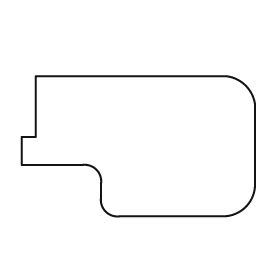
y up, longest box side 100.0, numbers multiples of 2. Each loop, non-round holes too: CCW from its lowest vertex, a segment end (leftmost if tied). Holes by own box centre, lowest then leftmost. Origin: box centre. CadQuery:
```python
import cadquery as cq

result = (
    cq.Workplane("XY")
    .moveTo(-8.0, -30.0)
    .lineTo(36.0, -30.0)
    .threePointArc((46.0, -26.0), (50.0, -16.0))
    .lineTo(50.0, 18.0)
    .threePointArc((46.0, 26.0), (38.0, 30.0))
    .lineTo(-44.0, 30.0)
    .lineTo(-44.0, 4.0)
    .lineTo(-50.0, 4.0)
    .lineTo(-50.0, -8.0)
    .lineTo(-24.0, -8.0)
    .threePointArc((-18.0, -10.0), (-16.0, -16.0))
    .lineTo(-16.0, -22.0)
    .threePointArc((-14.0, -28.0), (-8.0, -30.0))
    .close()
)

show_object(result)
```